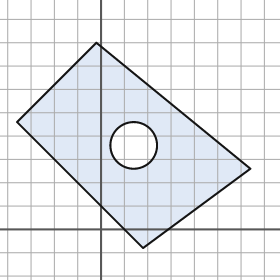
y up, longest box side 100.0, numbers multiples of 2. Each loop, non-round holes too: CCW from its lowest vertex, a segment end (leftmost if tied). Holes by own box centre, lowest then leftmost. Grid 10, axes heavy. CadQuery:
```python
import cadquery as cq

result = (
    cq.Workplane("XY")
    .moveTo(18.0, -8.0)
    .lineTo(64.0, 26.0)
    .lineTo(-2.0, 80.0)
    .lineTo(-36.0, 46.0)
    .close()
    .moveTo(14.0, 36.0)
    .circle(10.0)
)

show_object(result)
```